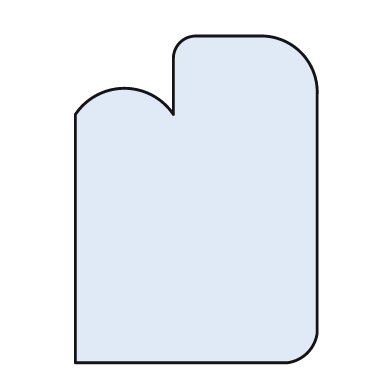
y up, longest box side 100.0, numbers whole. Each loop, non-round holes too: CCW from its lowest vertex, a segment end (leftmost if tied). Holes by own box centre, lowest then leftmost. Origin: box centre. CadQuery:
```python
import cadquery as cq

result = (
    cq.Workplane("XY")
    .moveTo(-37.0, -50.0)
    .lineTo(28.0, -50.0)
    .threePointArc((34.0, -47.0), (37.0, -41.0))
    .lineTo(37.0, 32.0)
    .threePointArc((32.0, 45.0), (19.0, 50.0))
    .lineTo(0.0, 50.0)
    .threePointArc((-5.0, 48.0), (-7.0, 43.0))
    .lineTo(-7.0, 26.0)
    .threePointArc((-22.0, 34.0), (-37.0, 26.0))
    .close()
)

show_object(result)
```